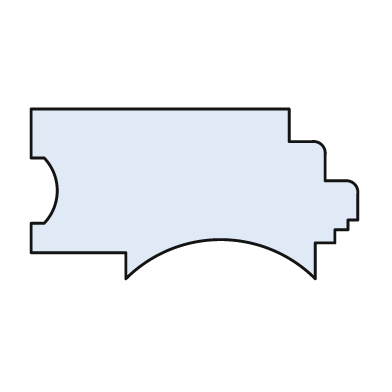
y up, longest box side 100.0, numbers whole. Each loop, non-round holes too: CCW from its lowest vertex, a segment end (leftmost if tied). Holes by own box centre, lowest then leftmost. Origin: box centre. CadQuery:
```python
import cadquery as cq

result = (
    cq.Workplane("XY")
    .moveTo(-21.0, -26.0)
    .threePointArc((8.0, -14.0), (37.0, -26.0))
    .lineTo(37.0, -15.0)
    .lineTo(43.0, -15.0)
    .lineTo(43.0, -11.0)
    .lineTo(47.0, -11.0)
    .lineTo(47.0, -8.0)
    .lineTo(50.0, -8.0)
    .lineTo(50.0, 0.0)
    .threePointArc((49.0, 3.0), (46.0, 4.0))
    .lineTo(40.0, 4.0)
    .lineTo(40.0, 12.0)
    .threePointArc((39.0, 15.0), (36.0, 16.0))
    .lineTo(29.0, 16.0)
    .lineTo(29.0, 26.0)
    .lineTo(-50.0, 26.0)
    .lineTo(-50.0, 11.0)
    .lineTo(-46.0, 11.0)
    .threePointArc((-42.0, 1.0), (-46.0, -9.0))
    .lineTo(-50.0, -9.0)
    .lineTo(-50.0, -18.0)
    .lineTo(-21.0, -18.0)
    .close()
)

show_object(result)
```